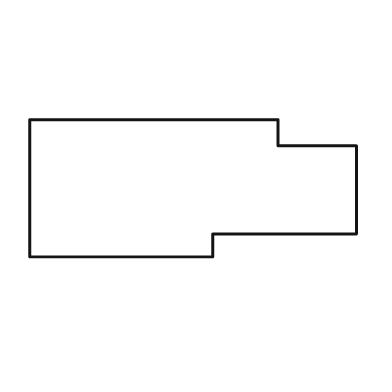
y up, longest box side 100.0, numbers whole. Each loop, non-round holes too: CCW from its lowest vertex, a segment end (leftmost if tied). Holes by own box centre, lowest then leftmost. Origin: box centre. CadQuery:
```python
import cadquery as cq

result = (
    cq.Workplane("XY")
    .moveTo(-50.0, -21.0)
    .lineTo(6.0, -21.0)
    .lineTo(6.0, -14.0)
    .lineTo(50.0, -14.0)
    .lineTo(50.0, 13.0)
    .lineTo(26.0, 13.0)
    .lineTo(26.0, 21.0)
    .lineTo(-50.0, 21.0)
    .close()
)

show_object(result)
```